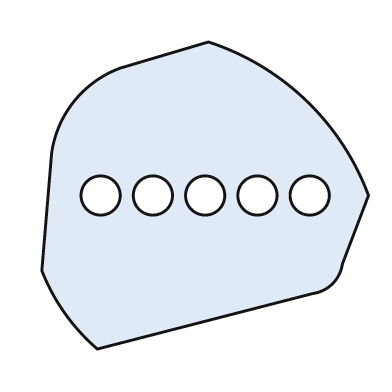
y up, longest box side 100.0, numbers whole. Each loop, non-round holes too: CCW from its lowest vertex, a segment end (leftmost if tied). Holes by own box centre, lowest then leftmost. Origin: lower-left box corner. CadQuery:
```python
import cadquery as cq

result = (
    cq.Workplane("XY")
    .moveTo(17.0, 0.0)
    .lineTo(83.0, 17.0)
    .threePointArc((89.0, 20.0), (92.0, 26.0))
    .lineTo(100.0, 47.0)
    .threePointArc((81.0, 76.0), (51.0, 94.0))
    .lineTo(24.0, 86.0)
    .threePointArc((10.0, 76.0), (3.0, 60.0))
    .lineTo(0.0, 24.0)
    .threePointArc((7.0, 11.0), (17.0, 0.0))
    .close()
    .moveTo(18.0, 47.0)
    .circle(6.0)
    .moveTo(34.0, 47.0)
    .circle(6.0)
    .moveTo(50.0, 47.0)
    .circle(6.0)
    .moveTo(66.0, 47.0)
    .circle(6.0)
    .moveTo(82.0, 47.0)
    .circle(6.0)
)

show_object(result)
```